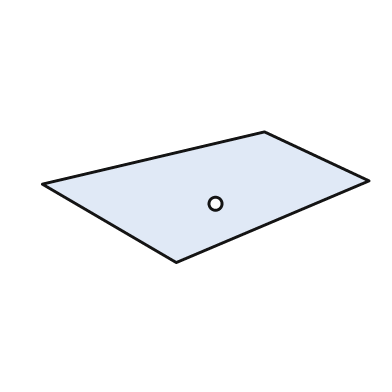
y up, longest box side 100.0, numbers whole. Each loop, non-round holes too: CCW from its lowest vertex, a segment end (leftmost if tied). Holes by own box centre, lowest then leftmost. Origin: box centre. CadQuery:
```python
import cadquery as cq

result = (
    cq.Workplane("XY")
    .moveTo(-9.0, -20.0)
    .lineTo(50.0, 5.0)
    .lineTo(18.0, 20.0)
    .lineTo(-50.0, 4.0)
    .close()
    .moveTo(3.0, -2.0)
    .circle(2.0)
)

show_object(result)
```